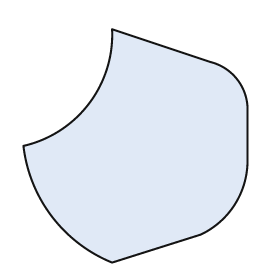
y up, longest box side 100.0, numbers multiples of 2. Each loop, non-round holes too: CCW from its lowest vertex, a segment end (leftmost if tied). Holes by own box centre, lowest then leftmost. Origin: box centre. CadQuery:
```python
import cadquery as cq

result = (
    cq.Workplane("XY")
    .moveTo(-10.0, -50.0)
    .lineTo(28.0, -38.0)
    .threePointArc((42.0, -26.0), (48.0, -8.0))
    .lineTo(48.0, 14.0)
    .threePointArc((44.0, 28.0), (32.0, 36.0))
    .lineTo(-10.0, 50.0)
    .threePointArc((-20.0, 18.0), (-48.0, 0.0))
    .threePointArc((-36.0, -30.0), (-10.0, -50.0))
    .close()
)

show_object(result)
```